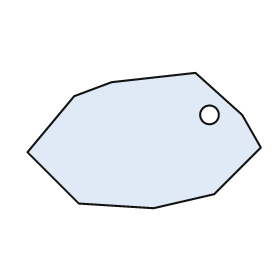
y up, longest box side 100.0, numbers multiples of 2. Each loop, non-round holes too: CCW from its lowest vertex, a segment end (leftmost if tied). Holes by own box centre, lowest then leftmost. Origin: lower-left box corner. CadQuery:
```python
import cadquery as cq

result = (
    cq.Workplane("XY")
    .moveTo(54.0, 0.0)
    .lineTo(80.0, 6.0)
    .lineTo(100.0, 26.0)
    .lineTo(92.0, 40.0)
    .lineTo(72.0, 58.0)
    .lineTo(36.0, 54.0)
    .lineTo(20.0, 48.0)
    .lineTo(0.0, 24.0)
    .lineTo(22.0, 2.0)
    .close()
    .moveTo(78.0, 40.0)
    .circle(4.0)
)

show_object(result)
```